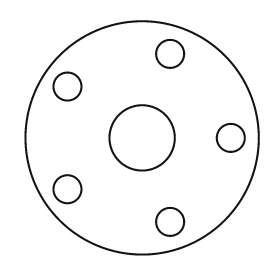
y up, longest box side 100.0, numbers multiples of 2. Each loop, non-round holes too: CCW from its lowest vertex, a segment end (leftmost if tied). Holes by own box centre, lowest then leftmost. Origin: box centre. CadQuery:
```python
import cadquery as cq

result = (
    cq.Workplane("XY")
    .moveTo(0.0, 0.0)
    .circle(50.0)
    .moveTo(12.0, -36.0)
    .circle(6.0)
    .moveTo(-32.0, -22.0)
    .circle(6.0)
    .moveTo(0.0, 0.0)
    .circle(14.0)
    .moveTo(38.0, 0.0)
    .circle(6.0)
    .moveTo(-32.0, 22.0)
    .circle(6.0)
    .moveTo(12.0, 36.0)
    .circle(6.0)
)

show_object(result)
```